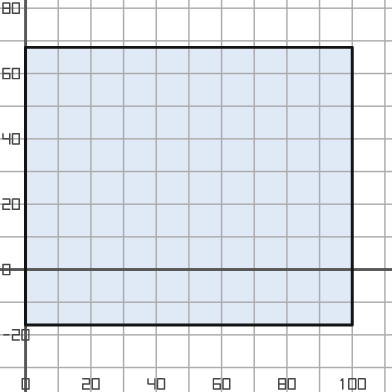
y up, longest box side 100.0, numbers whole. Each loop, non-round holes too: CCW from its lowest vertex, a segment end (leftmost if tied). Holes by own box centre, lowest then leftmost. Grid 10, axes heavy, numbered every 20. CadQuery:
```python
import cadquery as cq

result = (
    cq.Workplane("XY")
    .moveTo(0.0, -17.0)
    .lineTo(100.0, -17.0)
    .lineTo(100.0, 68.0)
    .lineTo(0.0, 68.0)
    .close()
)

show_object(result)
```